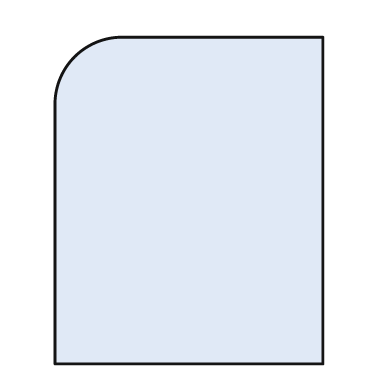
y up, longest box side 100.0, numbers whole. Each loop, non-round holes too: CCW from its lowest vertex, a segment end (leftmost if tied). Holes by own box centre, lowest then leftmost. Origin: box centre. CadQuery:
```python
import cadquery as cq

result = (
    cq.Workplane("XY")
    .moveTo(-41.0, -50.0)
    .lineTo(41.0, -50.0)
    .lineTo(41.0, 50.0)
    .lineTo(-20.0, 50.0)
    .threePointArc((-35.0, 44.0), (-41.0, 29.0))
    .close()
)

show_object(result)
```